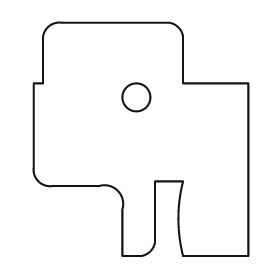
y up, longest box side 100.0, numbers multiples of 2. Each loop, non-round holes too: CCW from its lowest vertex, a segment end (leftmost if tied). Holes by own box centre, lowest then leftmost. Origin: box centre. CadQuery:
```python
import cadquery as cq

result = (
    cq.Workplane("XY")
    .moveTo(-8.0, -50.0)
    .lineTo(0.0, -50.0)
    .threePointArc((4.0, -48.0), (6.0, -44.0))
    .lineTo(6.0, -18.0)
    .lineTo(18.0, -18.0)
    .threePointArc((16.0, -34.0), (18.0, -50.0))
    .lineTo(46.0, -50.0)
    .lineTo(46.0, 24.0)
    .lineTo(18.0, 24.0)
    .lineTo(18.0, 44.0)
    .threePointArc((16.0, 48.0), (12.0, 50.0))
    .lineTo(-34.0, 50.0)
    .threePointArc((-40.0, 48.0), (-42.0, 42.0))
    .lineTo(-42.0, 24.0)
    .lineTo(-46.0, 24.0)
    .lineTo(-46.0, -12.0)
    .threePointArc((-44.0, -18.0), (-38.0, -20.0))
    .lineTo(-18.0, -20.0)
    .threePointArc((-10.0, -22.0), (-8.0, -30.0))
    .close()
    .moveTo(-2.0, 18.0)
    .circle(6.0)
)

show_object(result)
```